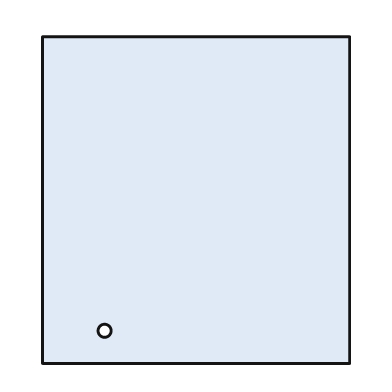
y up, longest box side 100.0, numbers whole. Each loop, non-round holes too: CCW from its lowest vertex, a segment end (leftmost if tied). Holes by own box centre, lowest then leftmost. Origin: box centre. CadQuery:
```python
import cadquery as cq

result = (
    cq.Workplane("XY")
    .moveTo(-47.0, -50.0)
    .lineTo(47.0, -50.0)
    .lineTo(47.0, 50.0)
    .lineTo(-47.0, 50.0)
    .close()
    .moveTo(-28.0, -40.0)
    .circle(2.0)
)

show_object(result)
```